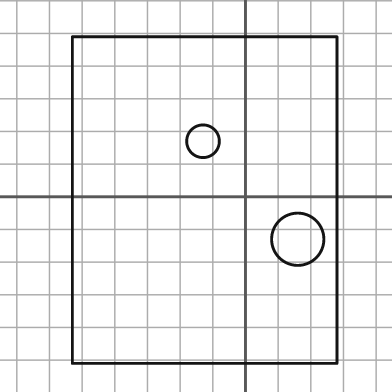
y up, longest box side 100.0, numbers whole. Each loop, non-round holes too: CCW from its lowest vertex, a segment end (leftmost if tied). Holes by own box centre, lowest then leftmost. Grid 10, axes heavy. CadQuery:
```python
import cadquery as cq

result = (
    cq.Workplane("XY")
    .moveTo(-53.0, -51.0)
    .lineTo(28.0, -51.0)
    .lineTo(28.0, 49.0)
    .lineTo(-53.0, 49.0)
    .close()
    .moveTo(16.0, -13.0)
    .circle(8.0)
    .moveTo(-13.0, 17.0)
    .circle(5.0)
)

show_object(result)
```